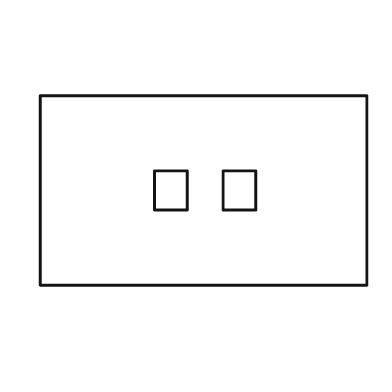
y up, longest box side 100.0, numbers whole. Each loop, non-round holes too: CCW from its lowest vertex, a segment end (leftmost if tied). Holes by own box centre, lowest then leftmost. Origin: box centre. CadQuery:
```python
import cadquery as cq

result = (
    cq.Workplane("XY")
    .moveTo(-50.0, -29.0)
    .lineTo(50.0, -29.0)
    .lineTo(50.0, 29.0)
    .lineTo(-50.0, 29.0)
    .close()
    .moveTo(-15.0, -6.0)
    .lineTo(-5.0, -6.0)
    .lineTo(-5.0, 6.0)
    .lineTo(-15.0, 6.0)
    .close()
    .moveTo(6.0, -6.0)
    .lineTo(16.0, -6.0)
    .lineTo(16.0, 6.0)
    .lineTo(6.0, 6.0)
    .close()
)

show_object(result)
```